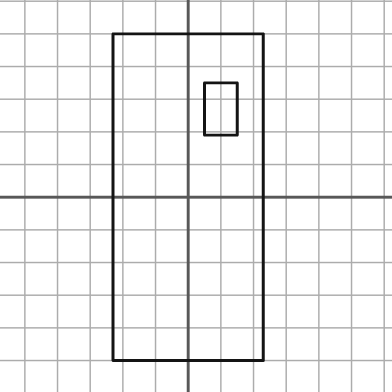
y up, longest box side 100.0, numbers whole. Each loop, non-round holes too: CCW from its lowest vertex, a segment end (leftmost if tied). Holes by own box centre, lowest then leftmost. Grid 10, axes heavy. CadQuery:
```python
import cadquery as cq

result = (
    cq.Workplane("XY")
    .moveTo(-23.0, -50.0)
    .lineTo(23.0, -50.0)
    .lineTo(23.0, 50.0)
    .lineTo(-23.0, 50.0)
    .close()
    .moveTo(5.0, 19.0)
    .lineTo(15.0, 19.0)
    .lineTo(15.0, 35.0)
    .lineTo(5.0, 35.0)
    .close()
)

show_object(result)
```